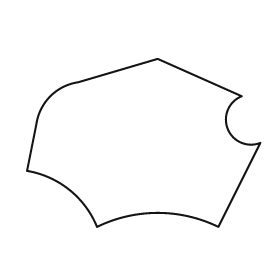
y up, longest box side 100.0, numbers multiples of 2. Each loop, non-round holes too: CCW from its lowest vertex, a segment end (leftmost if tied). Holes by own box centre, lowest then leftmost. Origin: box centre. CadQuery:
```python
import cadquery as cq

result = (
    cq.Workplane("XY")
    .moveTo(-20.0, -36.0)
    .threePointArc((6.0, -30.0), (32.0, -36.0))
    .lineTo(50.0, 0.0)
    .threePointArc((36.0, 6.0), (42.0, 20.0))
    .lineTo(6.0, 36.0)
    .lineTo(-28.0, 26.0)
    .threePointArc((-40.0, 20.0), (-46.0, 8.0))
    .lineTo(-50.0, -12.0)
    .threePointArc((-32.0, -20.0), (-20.0, -36.0))
    .close()
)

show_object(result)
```